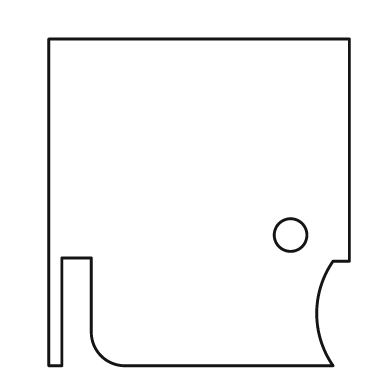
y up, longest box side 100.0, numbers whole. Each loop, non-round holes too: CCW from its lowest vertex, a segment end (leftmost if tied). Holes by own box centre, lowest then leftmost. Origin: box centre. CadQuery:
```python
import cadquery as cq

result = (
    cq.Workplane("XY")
    .moveTo(-46.0, -50.0)
    .lineTo(-42.0, -50.0)
    .lineTo(-42.0, -17.0)
    .lineTo(-33.0, -17.0)
    .lineTo(-33.0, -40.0)
    .threePointArc((-30.0, -47.0), (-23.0, -50.0))
    .lineTo(41.0, -50.0)
    .threePointArc((36.0, -34.0), (41.0, -18.0))
    .lineTo(46.0, -18.0)
    .lineTo(46.0, 50.0)
    .lineTo(-46.0, 50.0)
    .close()
    .moveTo(28.0, -10.0)
    .circle(5.0)
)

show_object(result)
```